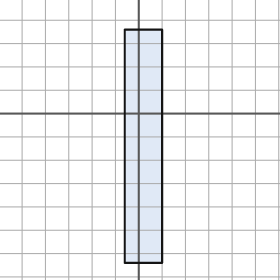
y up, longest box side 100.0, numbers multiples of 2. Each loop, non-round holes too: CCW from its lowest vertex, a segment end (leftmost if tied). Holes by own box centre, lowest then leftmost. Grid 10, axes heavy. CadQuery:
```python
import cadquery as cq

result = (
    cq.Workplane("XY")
    .moveTo(-6.0, -64.0)
    .lineTo(10.0, -64.0)
    .lineTo(10.0, 36.0)
    .lineTo(-6.0, 36.0)
    .close()
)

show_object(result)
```